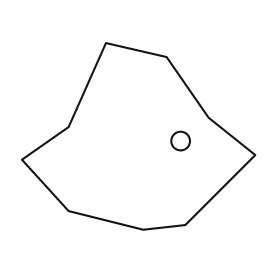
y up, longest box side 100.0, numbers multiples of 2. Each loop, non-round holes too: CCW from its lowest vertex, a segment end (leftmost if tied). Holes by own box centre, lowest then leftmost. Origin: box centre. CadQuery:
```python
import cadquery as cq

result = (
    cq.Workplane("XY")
    .moveTo(2.0, -40.0)
    .lineTo(20.0, -38.0)
    .lineTo(50.0, -8.0)
    .lineTo(30.0, 8.0)
    .lineTo(12.0, 34.0)
    .lineTo(-14.0, 40.0)
    .lineTo(-30.0, 4.0)
    .lineTo(-50.0, -10.0)
    .lineTo(-30.0, -32.0)
    .close()
    .moveTo(18.0, -2.0)
    .circle(4.0)
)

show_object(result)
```